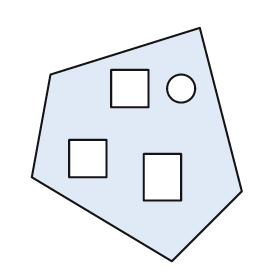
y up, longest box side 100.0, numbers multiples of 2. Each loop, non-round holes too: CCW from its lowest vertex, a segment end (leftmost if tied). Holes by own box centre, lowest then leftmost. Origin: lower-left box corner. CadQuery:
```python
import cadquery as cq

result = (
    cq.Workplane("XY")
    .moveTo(60.0, 0.0)
    .lineTo(90.0, 30.0)
    .lineTo(72.0, 100.0)
    .lineTo(8.0, 80.0)
    .lineTo(0.0, 36.0)
    .close()
    .moveTo(48.0, 26.0)
    .lineTo(64.0, 26.0)
    .lineTo(64.0, 46.0)
    .lineTo(48.0, 46.0)
    .close()
    .moveTo(16.0, 36.0)
    .lineTo(32.0, 36.0)
    .lineTo(32.0, 52.0)
    .lineTo(16.0, 52.0)
    .close()
    .moveTo(34.0, 66.0)
    .lineTo(50.0, 66.0)
    .lineTo(50.0, 82.0)
    .lineTo(34.0, 82.0)
    .close()
    .moveTo(64.0, 74.0)
    .circle(6.0)
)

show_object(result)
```